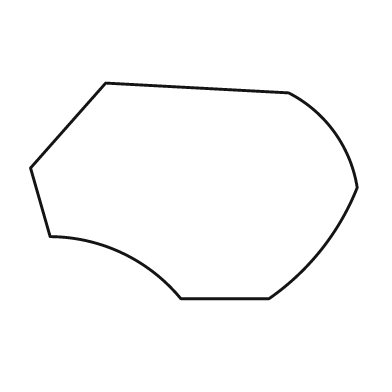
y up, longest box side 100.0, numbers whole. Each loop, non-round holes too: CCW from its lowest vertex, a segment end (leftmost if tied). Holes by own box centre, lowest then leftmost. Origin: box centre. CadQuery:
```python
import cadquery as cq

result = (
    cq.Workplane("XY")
    .moveTo(-4.0, -33.0)
    .lineTo(23.0, -33.0)
    .threePointArc((39.0, -18.0), (50.0, 1.0))
    .threePointArc((43.0, 18.0), (29.0, 30.0))
    .lineTo(-27.0, 33.0)
    .lineTo(-50.0, 7.0)
    .lineTo(-44.0, -14.0)
    .threePointArc((-22.0, -19.0), (-4.0, -33.0))
    .close()
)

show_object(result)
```